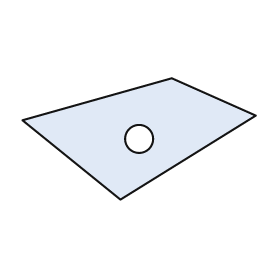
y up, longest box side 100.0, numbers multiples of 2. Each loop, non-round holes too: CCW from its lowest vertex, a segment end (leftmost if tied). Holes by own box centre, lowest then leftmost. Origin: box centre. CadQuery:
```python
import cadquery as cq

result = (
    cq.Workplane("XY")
    .moveTo(-8.0, -26.0)
    .lineTo(50.0, 10.0)
    .lineTo(14.0, 26.0)
    .lineTo(-50.0, 8.0)
    .close()
    .moveTo(0.0, 0.0)
    .circle(6.0)
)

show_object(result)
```